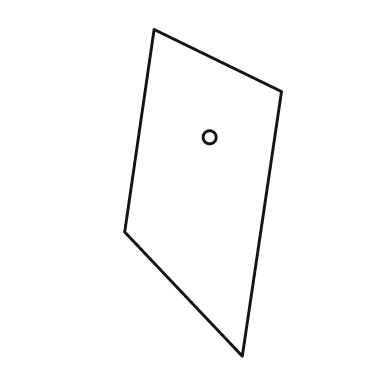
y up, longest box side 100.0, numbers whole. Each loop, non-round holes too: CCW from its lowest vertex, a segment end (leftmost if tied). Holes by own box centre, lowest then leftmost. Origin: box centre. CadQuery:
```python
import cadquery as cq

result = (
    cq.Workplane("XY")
    .moveTo(12.0, -50.0)
    .lineTo(24.0, 31.0)
    .lineTo(-15.0, 50.0)
    .lineTo(-24.0, -12.0)
    .close()
    .moveTo(2.0, 17.0)
    .circle(2.0)
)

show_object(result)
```